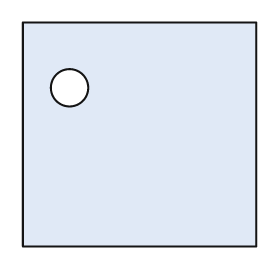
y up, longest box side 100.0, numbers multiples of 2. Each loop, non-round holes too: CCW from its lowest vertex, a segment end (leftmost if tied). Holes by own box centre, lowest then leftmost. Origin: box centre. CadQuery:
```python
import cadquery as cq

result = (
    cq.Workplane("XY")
    .moveTo(-50.0, -48.0)
    .lineTo(50.0, -48.0)
    .lineTo(50.0, 48.0)
    .lineTo(-50.0, 48.0)
    .close()
    .moveTo(-30.0, 20.0)
    .circle(8.0)
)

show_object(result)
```